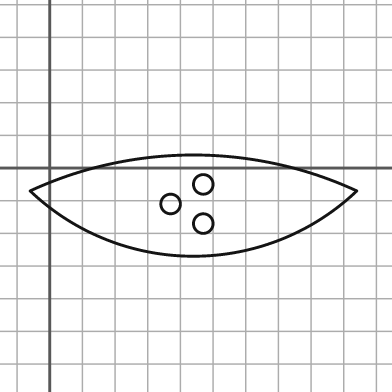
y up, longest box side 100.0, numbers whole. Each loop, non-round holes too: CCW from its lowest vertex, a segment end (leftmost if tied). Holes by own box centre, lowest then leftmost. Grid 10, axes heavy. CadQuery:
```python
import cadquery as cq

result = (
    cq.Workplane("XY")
    .moveTo(-6.0, -7.0)
    .threePointArc((44.0, -27.0), (94.0, -7.0))
    .threePointArc((44.0, 4.0), (-6.0, -7.0))
    .close()
    .moveTo(47.0, -17.0)
    .circle(3.0)
    .moveTo(37.0, -11.0)
    .circle(3.0)
    .moveTo(47.0, -5.0)
    .circle(3.0)
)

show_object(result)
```